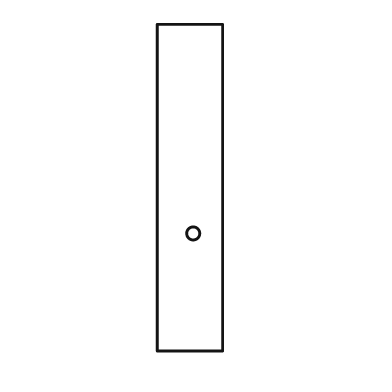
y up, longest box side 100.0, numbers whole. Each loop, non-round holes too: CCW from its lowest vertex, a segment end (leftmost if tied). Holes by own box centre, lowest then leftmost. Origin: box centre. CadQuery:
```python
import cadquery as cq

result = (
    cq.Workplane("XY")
    .moveTo(-10.0, -50.0)
    .lineTo(10.0, -50.0)
    .lineTo(10.0, 50.0)
    .lineTo(-10.0, 50.0)
    .close()
    .moveTo(1.0, -14.0)
    .circle(2.0)
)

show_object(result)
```